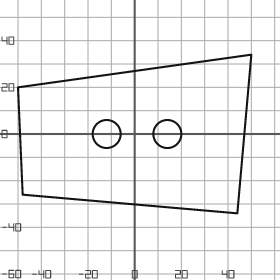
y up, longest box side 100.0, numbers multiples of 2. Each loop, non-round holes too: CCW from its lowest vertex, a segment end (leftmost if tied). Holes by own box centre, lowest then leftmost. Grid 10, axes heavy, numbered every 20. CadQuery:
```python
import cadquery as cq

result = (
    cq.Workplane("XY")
    .moveTo(44.0, -34.0)
    .lineTo(50.0, 34.0)
    .lineTo(-50.0, 20.0)
    .lineTo(-48.0, -26.0)
    .close()
    .moveTo(-12.0, 0.0)
    .circle(6.0)
    .moveTo(14.0, 0.0)
    .circle(6.0)
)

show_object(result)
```